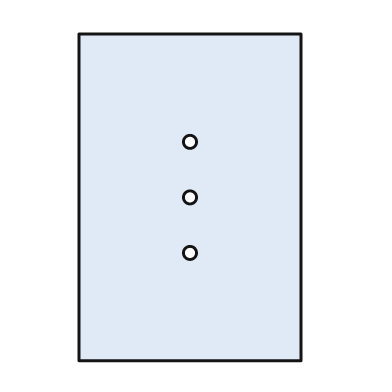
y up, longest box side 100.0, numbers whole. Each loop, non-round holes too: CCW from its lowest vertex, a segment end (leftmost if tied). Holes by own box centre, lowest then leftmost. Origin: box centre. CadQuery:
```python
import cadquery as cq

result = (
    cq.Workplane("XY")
    .moveTo(-34.0, -50.0)
    .lineTo(34.0, -50.0)
    .lineTo(34.0, 50.0)
    .lineTo(-34.0, 50.0)
    .close()
    .moveTo(0.0, -17.0)
    .circle(2.0)
    .moveTo(0.0, 0.0)
    .circle(2.0)
    .moveTo(0.0, 17.0)
    .circle(2.0)
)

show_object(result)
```